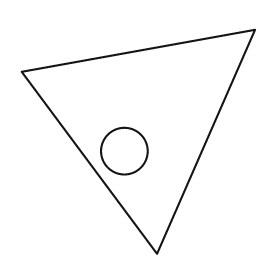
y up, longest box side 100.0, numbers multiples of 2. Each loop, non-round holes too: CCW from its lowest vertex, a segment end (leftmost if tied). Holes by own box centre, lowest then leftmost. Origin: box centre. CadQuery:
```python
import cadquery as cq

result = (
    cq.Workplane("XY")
    .moveTo(8.0, -48.0)
    .lineTo(50.0, 48.0)
    .lineTo(-50.0, 30.0)
    .close()
    .moveTo(-6.0, -4.0)
    .circle(10.0)
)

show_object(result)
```